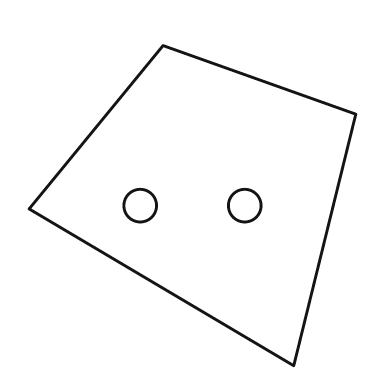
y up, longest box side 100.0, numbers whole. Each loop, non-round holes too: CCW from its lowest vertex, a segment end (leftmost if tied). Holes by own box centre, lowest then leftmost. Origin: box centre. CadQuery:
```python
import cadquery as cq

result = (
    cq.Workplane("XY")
    .moveTo(31.0, -49.0)
    .lineTo(50.0, 28.0)
    .lineTo(-9.0, 49.0)
    .lineTo(-50.0, -1.0)
    .close()
    .moveTo(-16.0, 0.0)
    .circle(5.0)
    .moveTo(16.0, 0.0)
    .circle(5.0)
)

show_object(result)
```